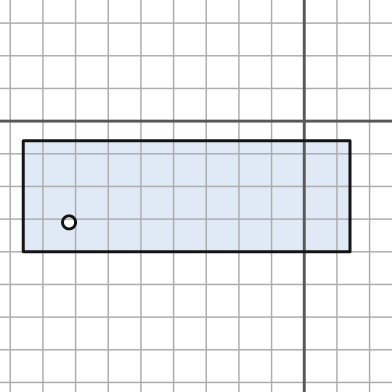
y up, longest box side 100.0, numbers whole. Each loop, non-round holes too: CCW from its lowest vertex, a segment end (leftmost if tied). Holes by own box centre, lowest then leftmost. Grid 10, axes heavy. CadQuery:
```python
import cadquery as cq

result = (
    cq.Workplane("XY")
    .moveTo(-86.0, -40.0)
    .lineTo(14.0, -40.0)
    .lineTo(14.0, -6.0)
    .lineTo(-86.0, -6.0)
    .close()
    .moveTo(-72.0, -31.0)
    .circle(2.0)
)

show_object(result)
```